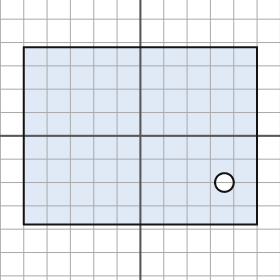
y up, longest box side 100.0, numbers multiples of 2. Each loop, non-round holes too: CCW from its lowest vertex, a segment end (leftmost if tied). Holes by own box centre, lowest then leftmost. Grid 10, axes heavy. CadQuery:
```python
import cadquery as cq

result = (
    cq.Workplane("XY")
    .moveTo(-50.0, -38.0)
    .lineTo(50.0, -38.0)
    .lineTo(50.0, 38.0)
    .lineTo(-50.0, 38.0)
    .close()
    .moveTo(36.0, -20.0)
    .circle(4.0)
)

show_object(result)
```